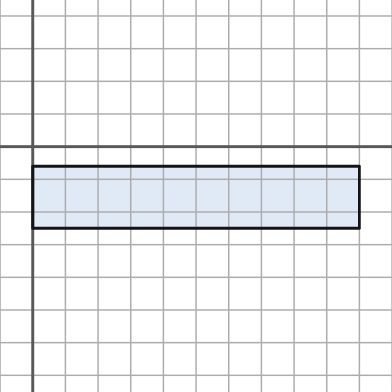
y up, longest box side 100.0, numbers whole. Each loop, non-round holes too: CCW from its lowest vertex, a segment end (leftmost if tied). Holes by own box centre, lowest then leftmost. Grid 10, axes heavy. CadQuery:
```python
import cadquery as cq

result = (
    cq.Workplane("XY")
    .moveTo(0.0, -25.0)
    .lineTo(100.0, -25.0)
    .lineTo(100.0, -6.0)
    .lineTo(0.0, -6.0)
    .close()
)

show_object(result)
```